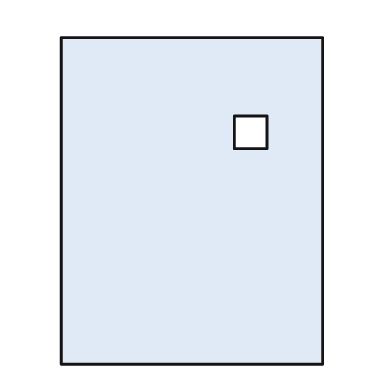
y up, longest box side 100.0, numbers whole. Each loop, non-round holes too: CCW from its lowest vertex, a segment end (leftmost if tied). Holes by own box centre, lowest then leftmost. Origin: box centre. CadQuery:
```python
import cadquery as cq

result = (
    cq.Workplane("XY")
    .moveTo(-40.0, -50.0)
    .lineTo(40.0, -50.0)
    .lineTo(40.0, 50.0)
    .lineTo(-40.0, 50.0)
    .close()
    .moveTo(13.0, 16.0)
    .lineTo(23.0, 16.0)
    .lineTo(23.0, 26.0)
    .lineTo(13.0, 26.0)
    .close()
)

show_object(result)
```